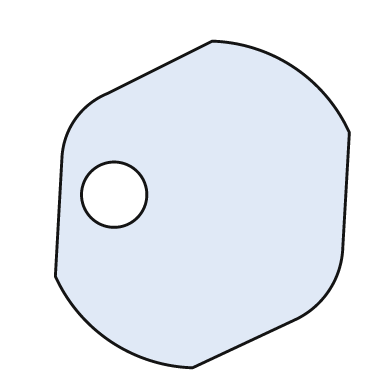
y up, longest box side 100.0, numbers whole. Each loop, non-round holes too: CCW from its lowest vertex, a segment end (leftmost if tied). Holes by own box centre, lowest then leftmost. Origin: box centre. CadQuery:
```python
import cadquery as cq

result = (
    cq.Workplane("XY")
    .moveTo(-3.0, -50.0)
    .lineTo(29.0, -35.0)
    .threePointArc((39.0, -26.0), (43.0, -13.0))
    .lineTo(45.0, 22.0)
    .threePointArc((28.0, 42.0), (3.0, 50.0))
    .lineTo(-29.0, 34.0)
    .threePointArc((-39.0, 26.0), (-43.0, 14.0))
    .lineTo(-45.0, -22.0)
    .threePointArc((-28.0, -42.0), (-3.0, -50.0))
    .close()
    .moveTo(-27.0, 3.0)
    .circle(10.0)
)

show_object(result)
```